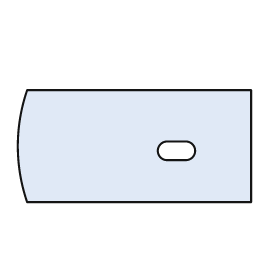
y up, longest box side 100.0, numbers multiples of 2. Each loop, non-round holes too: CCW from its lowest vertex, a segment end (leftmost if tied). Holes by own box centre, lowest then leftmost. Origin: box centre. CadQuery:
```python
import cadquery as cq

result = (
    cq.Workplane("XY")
    .moveTo(-46.0, -24.0)
    .lineTo(50.0, -24.0)
    .lineTo(50.0, 24.0)
    .lineTo(-46.0, 24.0)
    .threePointArc((-50.0, 0.0), (-46.0, -24.0))
    .close()
    .moveTo(14.0, -6.0)
    .lineTo(22.0, -6.0)
    .threePointArc((26.0, -2.0), (22.0, 2.0))
    .lineTo(14.0, 2.0)
    .threePointArc((10.0, -2.0), (14.0, -6.0))
    .close()
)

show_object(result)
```